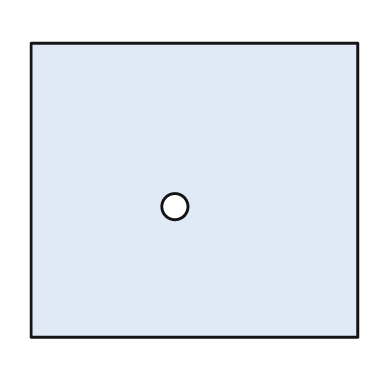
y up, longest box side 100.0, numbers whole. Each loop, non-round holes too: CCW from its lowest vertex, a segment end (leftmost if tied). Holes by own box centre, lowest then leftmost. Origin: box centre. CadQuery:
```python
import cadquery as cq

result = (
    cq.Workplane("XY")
    .moveTo(-50.0, -45.0)
    .lineTo(50.0, -45.0)
    .lineTo(50.0, 45.0)
    .lineTo(-50.0, 45.0)
    .close()
    .moveTo(-6.0, -5.0)
    .circle(4.0)
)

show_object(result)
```